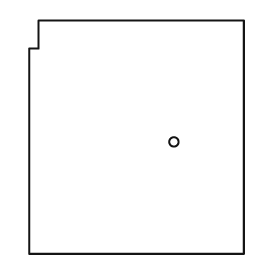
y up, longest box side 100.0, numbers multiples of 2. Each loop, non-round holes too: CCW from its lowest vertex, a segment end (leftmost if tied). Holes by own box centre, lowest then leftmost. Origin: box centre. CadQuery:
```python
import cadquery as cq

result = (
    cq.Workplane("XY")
    .moveTo(-46.0, -50.0)
    .lineTo(46.0, -50.0)
    .lineTo(46.0, 50.0)
    .lineTo(-42.0, 50.0)
    .lineTo(-42.0, 38.0)
    .lineTo(-46.0, 38.0)
    .close()
    .moveTo(16.0, -2.0)
    .circle(2.0)
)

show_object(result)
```